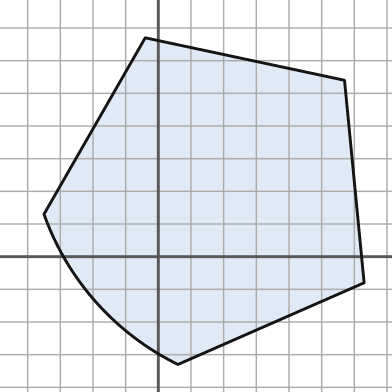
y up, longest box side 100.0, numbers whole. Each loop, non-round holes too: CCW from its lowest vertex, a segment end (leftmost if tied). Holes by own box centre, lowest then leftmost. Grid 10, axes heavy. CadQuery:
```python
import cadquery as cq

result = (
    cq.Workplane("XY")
    .moveTo(6.0, -33.0)
    .lineTo(63.0, -8.0)
    .lineTo(57.0, 54.0)
    .lineTo(-4.0, 67.0)
    .lineTo(-35.0, 13.0)
    .threePointArc((-19.0, -14.0), (6.0, -33.0))
    .close()
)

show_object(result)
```